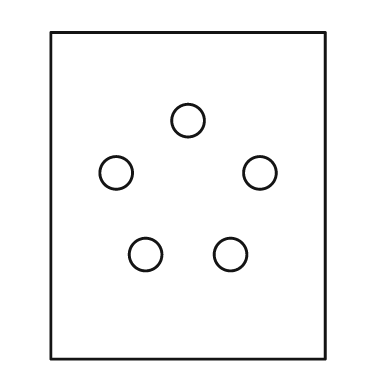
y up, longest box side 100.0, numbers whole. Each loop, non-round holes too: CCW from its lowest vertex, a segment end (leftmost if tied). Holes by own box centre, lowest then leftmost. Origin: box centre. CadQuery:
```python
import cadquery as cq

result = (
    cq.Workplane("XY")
    .moveTo(-42.0, -50.0)
    .lineTo(42.0, -50.0)
    .lineTo(42.0, 50.0)
    .lineTo(-42.0, 50.0)
    .close()
    .moveTo(-13.0, -18.0)
    .circle(5.0)
    .moveTo(13.0, -18.0)
    .circle(5.0)
    .moveTo(-22.0, 7.0)
    .circle(5.0)
    .moveTo(22.0, 7.0)
    .circle(5.0)
    .moveTo(0.0, 23.0)
    .circle(5.0)
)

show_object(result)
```